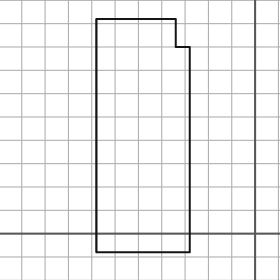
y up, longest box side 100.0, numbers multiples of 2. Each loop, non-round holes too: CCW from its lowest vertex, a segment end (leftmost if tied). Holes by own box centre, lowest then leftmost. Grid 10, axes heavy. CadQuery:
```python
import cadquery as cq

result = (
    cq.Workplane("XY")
    .moveTo(-68.0, -8.0)
    .lineTo(-28.0, -8.0)
    .lineTo(-28.0, 80.0)
    .lineTo(-34.0, 80.0)
    .lineTo(-34.0, 92.0)
    .lineTo(-68.0, 92.0)
    .close()
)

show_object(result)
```